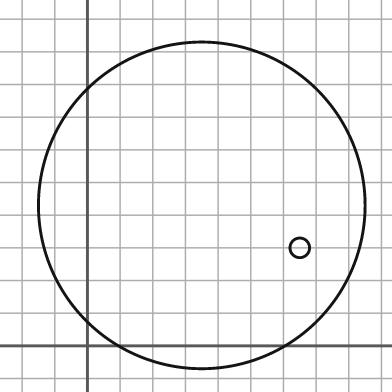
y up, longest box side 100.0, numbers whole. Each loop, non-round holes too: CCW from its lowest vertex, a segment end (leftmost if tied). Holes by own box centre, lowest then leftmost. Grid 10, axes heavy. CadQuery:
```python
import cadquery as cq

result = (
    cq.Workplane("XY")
    .moveTo(35.0, 43.0)
    .circle(50.0)
    .moveTo(65.0, 30.0)
    .circle(3.0)
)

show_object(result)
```